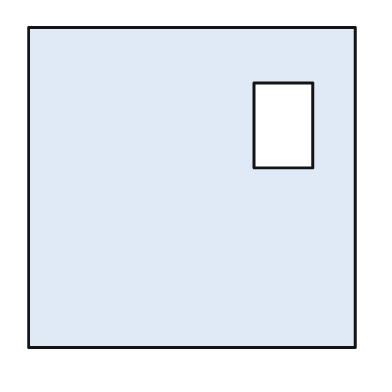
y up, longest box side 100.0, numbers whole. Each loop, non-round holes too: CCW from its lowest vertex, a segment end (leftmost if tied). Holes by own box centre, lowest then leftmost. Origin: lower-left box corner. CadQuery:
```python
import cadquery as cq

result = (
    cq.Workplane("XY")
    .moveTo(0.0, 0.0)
    .lineTo(100.0, 0.0)
    .lineTo(100.0, 98.0)
    .lineTo(0.0, 98.0)
    .close()
    .moveTo(69.0, 55.0)
    .lineTo(87.0, 55.0)
    .lineTo(87.0, 81.0)
    .lineTo(69.0, 81.0)
    .close()
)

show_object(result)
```